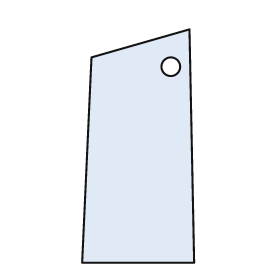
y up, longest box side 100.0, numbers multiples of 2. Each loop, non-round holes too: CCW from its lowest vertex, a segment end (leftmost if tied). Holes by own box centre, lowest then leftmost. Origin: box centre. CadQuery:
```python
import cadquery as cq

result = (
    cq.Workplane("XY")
    .moveTo(-24.0, -50.0)
    .lineTo(24.0, -50.0)
    .lineTo(22.0, 50.0)
    .lineTo(-20.0, 38.0)
    .close()
    .moveTo(14.0, 34.0)
    .circle(4.0)
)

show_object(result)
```